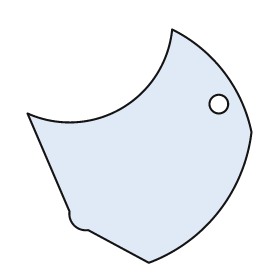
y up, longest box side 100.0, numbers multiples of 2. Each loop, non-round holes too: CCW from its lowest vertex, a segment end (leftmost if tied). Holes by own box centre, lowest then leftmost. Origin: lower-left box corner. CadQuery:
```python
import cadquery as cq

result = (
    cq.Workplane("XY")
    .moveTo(52.0, 0.0)
    .threePointArc((82.0, 22.0), (96.0, 56.0))
    .threePointArc((84.0, 82.0), (62.0, 100.0))
    .threePointArc((40.0, 66.0), (0.0, 64.0))
    .lineTo(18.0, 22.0)
    .threePointArc((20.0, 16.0), (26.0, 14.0))
    .close()
    .moveTo(82.0, 68.0)
    .circle(4.0)
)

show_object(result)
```